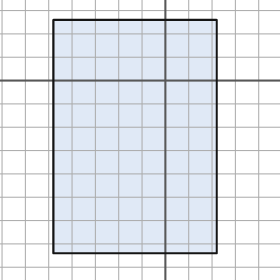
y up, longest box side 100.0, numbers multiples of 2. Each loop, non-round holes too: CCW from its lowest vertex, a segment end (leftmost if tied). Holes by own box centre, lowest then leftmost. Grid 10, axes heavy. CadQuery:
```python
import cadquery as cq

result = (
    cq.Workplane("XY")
    .moveTo(-48.0, -74.0)
    .lineTo(22.0, -74.0)
    .lineTo(22.0, 26.0)
    .lineTo(-48.0, 26.0)
    .close()
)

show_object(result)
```